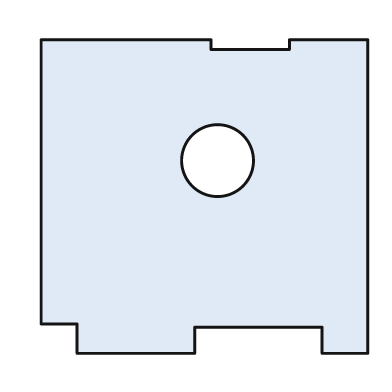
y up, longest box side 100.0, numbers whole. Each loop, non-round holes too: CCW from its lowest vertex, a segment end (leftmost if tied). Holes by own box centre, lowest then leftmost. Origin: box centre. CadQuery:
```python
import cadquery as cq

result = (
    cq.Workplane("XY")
    .moveTo(-39.0, -48.0)
    .lineTo(-3.0, -48.0)
    .lineTo(-3.0, -40.0)
    .lineTo(36.0, -40.0)
    .lineTo(36.0, -48.0)
    .lineTo(50.0, -48.0)
    .lineTo(50.0, 48.0)
    .lineTo(26.0, 48.0)
    .lineTo(26.0, 45.0)
    .lineTo(2.0, 45.0)
    .lineTo(2.0, 48.0)
    .lineTo(-50.0, 48.0)
    .lineTo(-50.0, -39.0)
    .lineTo(-39.0, -39.0)
    .close()
    .moveTo(4.0, 11.0)
    .circle(11.0)
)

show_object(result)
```